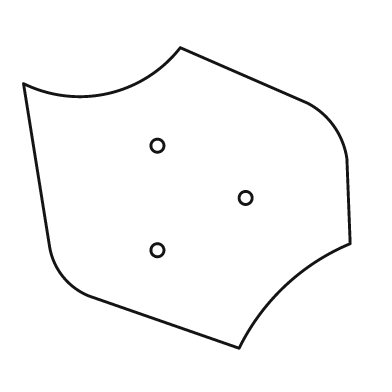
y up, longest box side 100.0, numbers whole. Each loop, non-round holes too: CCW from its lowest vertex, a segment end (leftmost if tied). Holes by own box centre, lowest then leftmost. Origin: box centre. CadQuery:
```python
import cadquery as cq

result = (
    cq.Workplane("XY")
    .moveTo(16.0, -46.0)
    .threePointArc((30.0, -27.0), (50.0, -14.0))
    .lineTo(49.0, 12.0)
    .threePointArc((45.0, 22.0), (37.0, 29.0))
    .lineTo(-2.0, 46.0)
    .threePointArc((-24.0, 32.0), (-50.0, 35.0))
    .lineTo(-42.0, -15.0)
    .threePointArc((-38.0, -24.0), (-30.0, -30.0))
    .close()
    .moveTo(-9.0, -16.0)
    .circle(2.0)
    .moveTo(18.0, 0.0)
    .circle(2.0)
    .moveTo(-9.0, 16.0)
    .circle(2.0)
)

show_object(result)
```